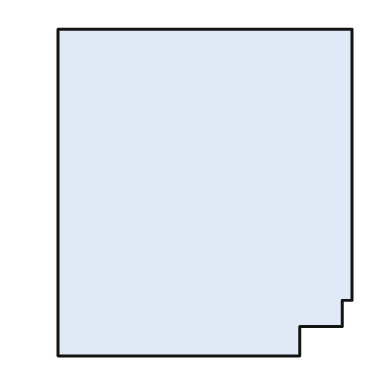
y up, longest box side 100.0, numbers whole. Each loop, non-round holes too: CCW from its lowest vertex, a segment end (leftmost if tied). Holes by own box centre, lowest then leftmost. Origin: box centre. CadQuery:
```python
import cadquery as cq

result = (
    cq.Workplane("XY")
    .moveTo(-45.0, -50.0)
    .lineTo(29.0, -50.0)
    .lineTo(29.0, -41.0)
    .lineTo(42.0, -41.0)
    .lineTo(42.0, -33.0)
    .lineTo(45.0, -33.0)
    .lineTo(45.0, 50.0)
    .lineTo(-45.0, 50.0)
    .close()
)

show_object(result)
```